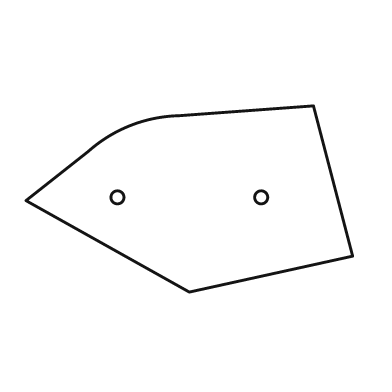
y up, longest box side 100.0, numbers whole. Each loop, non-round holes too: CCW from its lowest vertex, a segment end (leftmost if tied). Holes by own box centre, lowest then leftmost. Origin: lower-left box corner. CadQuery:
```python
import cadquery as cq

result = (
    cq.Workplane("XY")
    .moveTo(50.0, 0.0)
    .lineTo(100.0, 11.0)
    .lineTo(88.0, 57.0)
    .lineTo(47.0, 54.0)
    .threePointArc((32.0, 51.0), (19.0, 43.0))
    .lineTo(0.0, 28.0)
    .close()
    .moveTo(28.0, 29.0)
    .circle(2.0)
    .moveTo(72.0, 29.0)
    .circle(2.0)
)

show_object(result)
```